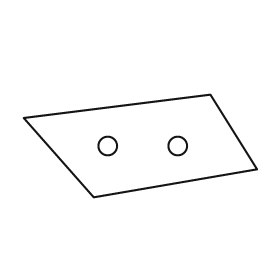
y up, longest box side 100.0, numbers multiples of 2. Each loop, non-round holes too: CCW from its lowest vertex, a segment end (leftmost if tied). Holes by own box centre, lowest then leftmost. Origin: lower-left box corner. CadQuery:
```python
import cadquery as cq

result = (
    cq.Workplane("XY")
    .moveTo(30.0, 0.0)
    .lineTo(100.0, 12.0)
    .lineTo(80.0, 44.0)
    .lineTo(0.0, 34.0)
    .close()
    .moveTo(36.0, 22.0)
    .circle(4.0)
    .moveTo(66.0, 22.0)
    .circle(4.0)
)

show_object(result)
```